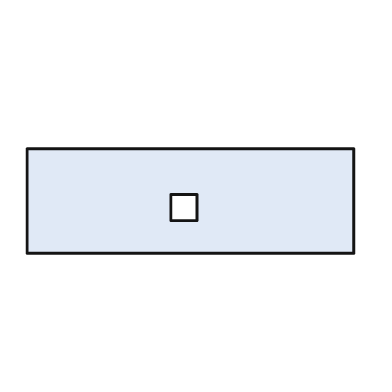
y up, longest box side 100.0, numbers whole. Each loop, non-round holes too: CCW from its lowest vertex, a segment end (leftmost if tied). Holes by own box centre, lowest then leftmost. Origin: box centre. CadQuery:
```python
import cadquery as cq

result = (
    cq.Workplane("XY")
    .moveTo(-50.0, -16.0)
    .lineTo(50.0, -16.0)
    .lineTo(50.0, 16.0)
    .lineTo(-50.0, 16.0)
    .close()
    .moveTo(-6.0, -6.0)
    .lineTo(2.0, -6.0)
    .lineTo(2.0, 2.0)
    .lineTo(-6.0, 2.0)
    .close()
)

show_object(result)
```